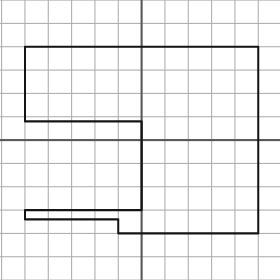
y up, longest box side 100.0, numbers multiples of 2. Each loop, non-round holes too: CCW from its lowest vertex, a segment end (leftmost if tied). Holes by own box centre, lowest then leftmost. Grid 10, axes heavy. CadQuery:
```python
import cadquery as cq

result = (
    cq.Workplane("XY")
    .moveTo(-10.0, -40.0)
    .lineTo(50.0, -40.0)
    .lineTo(50.0, 40.0)
    .lineTo(-50.0, 40.0)
    .lineTo(-50.0, 8.0)
    .lineTo(0.0, 8.0)
    .lineTo(0.0, -30.0)
    .lineTo(-50.0, -30.0)
    .lineTo(-50.0, -34.0)
    .lineTo(-10.0, -34.0)
    .close()
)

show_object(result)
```